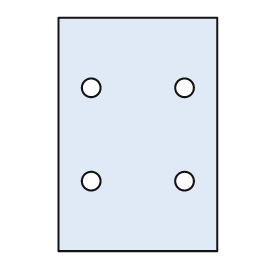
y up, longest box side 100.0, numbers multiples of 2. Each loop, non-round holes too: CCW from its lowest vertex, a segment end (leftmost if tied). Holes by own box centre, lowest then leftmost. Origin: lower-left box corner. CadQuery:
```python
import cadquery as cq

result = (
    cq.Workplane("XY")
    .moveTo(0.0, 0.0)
    .lineTo(68.0, 0.0)
    .lineTo(68.0, 100.0)
    .lineTo(0.0, 100.0)
    .close()
    .moveTo(14.0, 30.0)
    .circle(4.0)
    .moveTo(54.0, 30.0)
    .circle(4.0)
    .moveTo(14.0, 70.0)
    .circle(4.0)
    .moveTo(54.0, 70.0)
    .circle(4.0)
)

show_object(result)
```